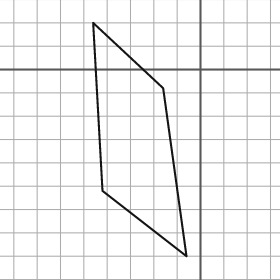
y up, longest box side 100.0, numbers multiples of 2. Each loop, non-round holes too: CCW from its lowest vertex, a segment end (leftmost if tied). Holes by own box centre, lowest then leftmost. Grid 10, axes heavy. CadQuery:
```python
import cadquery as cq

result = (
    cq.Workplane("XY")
    .moveTo(-6.0, -80.0)
    .lineTo(-16.0, -8.0)
    .lineTo(-46.0, 20.0)
    .lineTo(-42.0, -52.0)
    .close()
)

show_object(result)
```